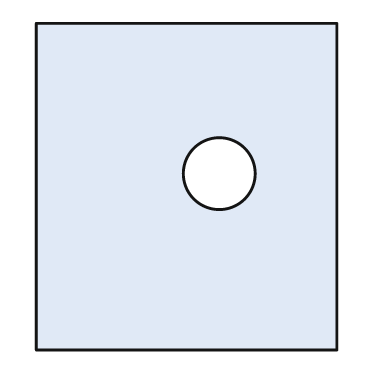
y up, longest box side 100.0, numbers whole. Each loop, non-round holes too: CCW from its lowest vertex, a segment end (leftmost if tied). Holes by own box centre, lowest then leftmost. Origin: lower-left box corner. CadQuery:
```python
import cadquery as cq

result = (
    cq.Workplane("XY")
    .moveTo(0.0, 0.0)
    .lineTo(92.0, 0.0)
    .lineTo(92.0, 100.0)
    .lineTo(0.0, 100.0)
    .close()
    .moveTo(56.0, 54.0)
    .circle(11.0)
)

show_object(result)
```